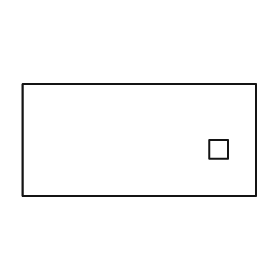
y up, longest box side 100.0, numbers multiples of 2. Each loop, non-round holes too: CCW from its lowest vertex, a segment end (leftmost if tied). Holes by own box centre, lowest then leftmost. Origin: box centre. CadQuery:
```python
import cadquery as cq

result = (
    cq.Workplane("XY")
    .moveTo(-50.0, -24.0)
    .lineTo(50.0, -24.0)
    .lineTo(50.0, 24.0)
    .lineTo(-50.0, 24.0)
    .close()
    .moveTo(30.0, -8.0)
    .lineTo(38.0, -8.0)
    .lineTo(38.0, 0.0)
    .lineTo(30.0, 0.0)
    .close()
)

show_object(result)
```